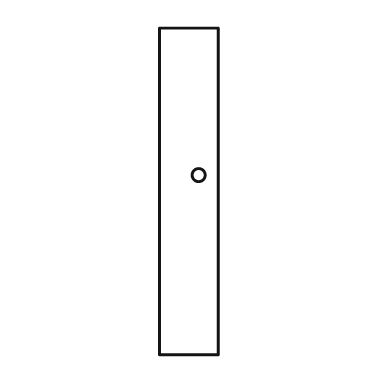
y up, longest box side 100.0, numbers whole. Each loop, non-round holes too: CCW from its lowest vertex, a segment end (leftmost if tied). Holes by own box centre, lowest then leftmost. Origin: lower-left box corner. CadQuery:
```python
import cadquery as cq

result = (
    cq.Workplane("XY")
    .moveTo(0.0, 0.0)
    .lineTo(18.0, 0.0)
    .lineTo(18.0, 100.0)
    .lineTo(0.0, 100.0)
    .close()
    .moveTo(12.0, 55.0)
    .circle(2.0)
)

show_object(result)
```